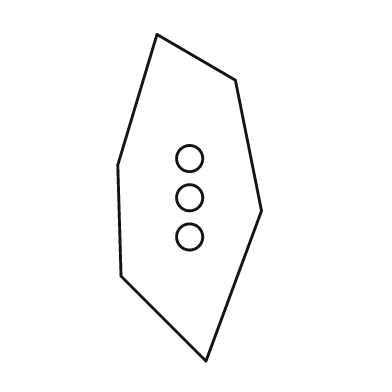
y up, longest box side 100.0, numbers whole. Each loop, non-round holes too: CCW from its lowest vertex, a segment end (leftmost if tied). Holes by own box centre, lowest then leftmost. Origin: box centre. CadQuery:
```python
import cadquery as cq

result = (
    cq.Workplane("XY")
    .moveTo(5.0, -50.0)
    .lineTo(22.0, -4.0)
    .lineTo(14.0, 36.0)
    .lineTo(-10.0, 50.0)
    .lineTo(-22.0, 10.0)
    .lineTo(-21.0, -24.0)
    .close()
    .moveTo(0.0, -12.0)
    .circle(4.0)
    .moveTo(0.0, 0.0)
    .circle(4.0)
    .moveTo(0.0, 12.0)
    .circle(4.0)
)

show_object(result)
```